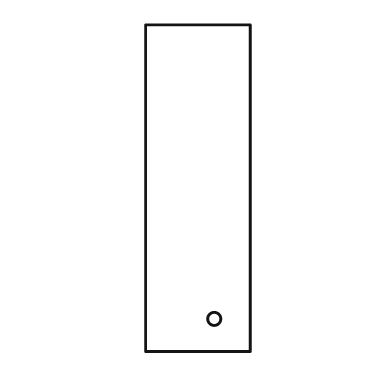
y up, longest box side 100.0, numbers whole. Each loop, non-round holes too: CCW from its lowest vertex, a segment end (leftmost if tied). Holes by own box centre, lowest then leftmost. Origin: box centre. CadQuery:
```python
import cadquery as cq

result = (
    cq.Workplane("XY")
    .moveTo(-16.0, -50.0)
    .lineTo(16.0, -50.0)
    .lineTo(16.0, 50.0)
    .lineTo(-16.0, 50.0)
    .close()
    .moveTo(5.0, -40.0)
    .circle(2.0)
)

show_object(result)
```